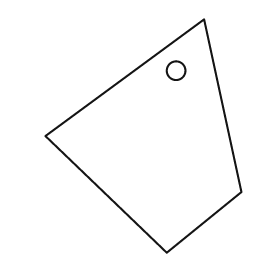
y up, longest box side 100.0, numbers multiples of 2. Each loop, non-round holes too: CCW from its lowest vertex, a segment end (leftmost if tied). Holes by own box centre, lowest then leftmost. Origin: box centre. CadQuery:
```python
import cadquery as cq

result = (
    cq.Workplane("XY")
    .moveTo(10.0, -50.0)
    .lineTo(42.0, -24.0)
    .lineTo(26.0, 50.0)
    .lineTo(-42.0, 0.0)
    .close()
    .moveTo(14.0, 28.0)
    .circle(4.0)
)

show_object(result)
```